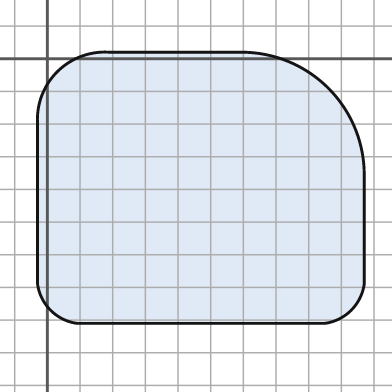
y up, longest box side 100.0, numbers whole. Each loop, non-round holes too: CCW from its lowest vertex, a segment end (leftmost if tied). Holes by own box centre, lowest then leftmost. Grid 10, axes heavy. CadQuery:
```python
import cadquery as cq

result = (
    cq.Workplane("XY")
    .moveTo(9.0, -81.0)
    .lineTo(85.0, -81.0)
    .threePointArc((93.0, -77.0), (97.0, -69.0))
    .lineTo(97.0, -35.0)
    .threePointArc((86.0, -9.0), (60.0, 2.0))
    .lineTo(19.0, 2.0)
    .threePointArc((3.0, -4.0), (-3.0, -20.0))
    .lineTo(-3.0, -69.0)
    .threePointArc((1.0, -77.0), (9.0, -81.0))
    .close()
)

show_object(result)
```